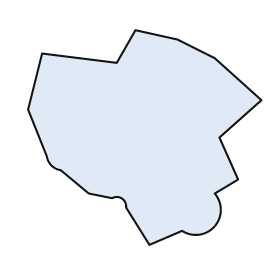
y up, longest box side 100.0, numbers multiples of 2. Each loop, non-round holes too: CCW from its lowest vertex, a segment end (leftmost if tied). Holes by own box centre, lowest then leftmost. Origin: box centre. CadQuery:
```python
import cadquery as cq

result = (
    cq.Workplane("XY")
    .moveTo(2.0, -46.0)
    .lineTo(16.0, -40.0)
    .threePointArc((30.0, -38.0), (30.0, -24.0))
    .lineTo(40.0, -18.0)
    .lineTo(32.0, 0.0)
    .lineTo(50.0, 16.0)
    .lineTo(30.0, 34.0)
    .lineTo(14.0, 42.0)
    .lineTo(-4.0, 46.0)
    .lineTo(-12.0, 32.0)
    .lineTo(-44.0, 36.0)
    .lineTo(-50.0, 12.0)
    .lineTo(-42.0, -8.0)
    .threePointArc((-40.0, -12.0), (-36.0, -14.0))
    .lineTo(-24.0, -24.0)
    .lineTo(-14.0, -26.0)
    .threePointArc((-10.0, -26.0), (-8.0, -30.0))
    .close()
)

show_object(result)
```